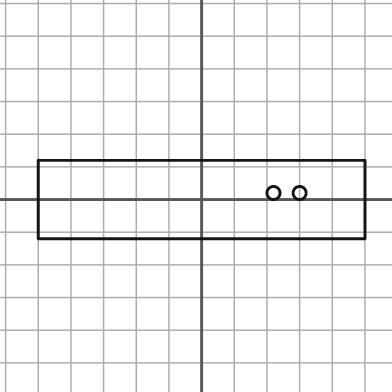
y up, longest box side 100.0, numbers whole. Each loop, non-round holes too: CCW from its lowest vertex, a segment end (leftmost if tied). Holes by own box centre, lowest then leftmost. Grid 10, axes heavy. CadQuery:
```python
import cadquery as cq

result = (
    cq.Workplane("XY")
    .moveTo(-50.0, -12.0)
    .lineTo(50.0, -12.0)
    .lineTo(50.0, 12.0)
    .lineTo(-50.0, 12.0)
    .close()
    .moveTo(22.0, 2.0)
    .circle(2.0)
    .moveTo(30.0, 2.0)
    .circle(2.0)
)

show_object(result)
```